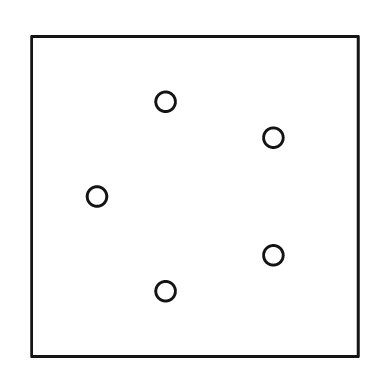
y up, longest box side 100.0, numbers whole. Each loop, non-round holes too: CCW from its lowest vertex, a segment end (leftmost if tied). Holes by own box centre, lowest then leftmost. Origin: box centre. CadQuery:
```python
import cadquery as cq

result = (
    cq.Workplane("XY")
    .moveTo(-50.0, -49.0)
    .lineTo(50.0, -49.0)
    .lineTo(50.0, 49.0)
    .lineTo(-50.0, 49.0)
    .close()
    .moveTo(-9.0, -29.0)
    .circle(3.0)
    .moveTo(24.0, -18.0)
    .circle(3.0)
    .moveTo(-30.0, 0.0)
    .circle(3.0)
    .moveTo(24.0, 18.0)
    .circle(3.0)
    .moveTo(-9.0, 29.0)
    .circle(3.0)
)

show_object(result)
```